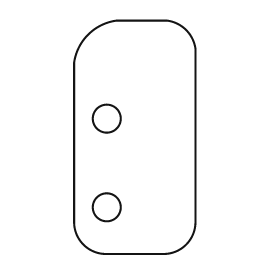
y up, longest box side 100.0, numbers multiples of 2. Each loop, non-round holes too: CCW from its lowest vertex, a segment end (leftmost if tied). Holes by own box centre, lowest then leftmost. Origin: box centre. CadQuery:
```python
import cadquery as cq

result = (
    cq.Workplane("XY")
    .moveTo(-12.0, -50.0)
    .lineTo(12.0, -50.0)
    .threePointArc((22.0, -46.0), (26.0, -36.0))
    .lineTo(26.0, 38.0)
    .threePointArc((22.0, 46.0), (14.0, 50.0))
    .lineTo(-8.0, 50.0)
    .threePointArc((-20.0, 44.0), (-26.0, 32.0))
    .lineTo(-26.0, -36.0)
    .threePointArc((-22.0, -46.0), (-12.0, -50.0))
    .close()
    .moveTo(-12.0, -30.0)
    .circle(6.0)
    .moveTo(-12.0, 8.0)
    .circle(6.0)
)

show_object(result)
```